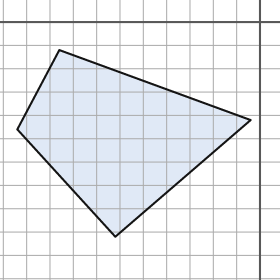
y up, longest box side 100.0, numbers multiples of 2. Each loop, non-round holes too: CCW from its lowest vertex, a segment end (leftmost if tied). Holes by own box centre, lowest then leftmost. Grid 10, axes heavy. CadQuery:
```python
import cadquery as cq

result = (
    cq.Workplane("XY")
    .moveTo(-62.0, -92.0)
    .lineTo(-4.0, -42.0)
    .lineTo(-86.0, -12.0)
    .lineTo(-104.0, -46.0)
    .close()
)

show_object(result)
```